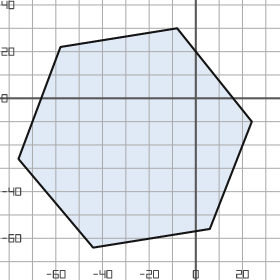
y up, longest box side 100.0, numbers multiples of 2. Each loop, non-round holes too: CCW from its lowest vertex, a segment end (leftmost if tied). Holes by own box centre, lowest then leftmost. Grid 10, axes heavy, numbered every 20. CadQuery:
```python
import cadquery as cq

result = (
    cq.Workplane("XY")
    .moveTo(-44.0, -64.0)
    .lineTo(6.0, -56.0)
    .lineTo(24.0, -10.0)
    .lineTo(-8.0, 30.0)
    .lineTo(-58.0, 22.0)
    .lineTo(-76.0, -26.0)
    .close()
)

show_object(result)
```